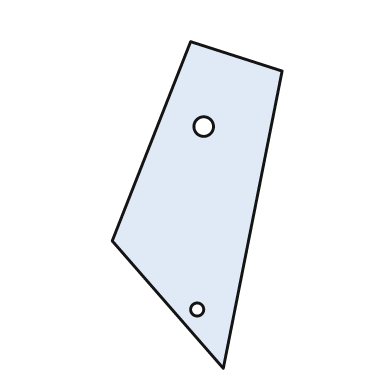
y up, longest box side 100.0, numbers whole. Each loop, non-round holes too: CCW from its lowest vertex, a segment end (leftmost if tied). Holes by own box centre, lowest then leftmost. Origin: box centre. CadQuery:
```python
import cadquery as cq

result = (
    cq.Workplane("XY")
    .moveTo(8.0, -50.0)
    .lineTo(26.0, 41.0)
    .lineTo(-2.0, 50.0)
    .lineTo(-26.0, -11.0)
    .close()
    .moveTo(0.0, -32.0)
    .circle(2.0)
    .moveTo(2.0, 24.0)
    .circle(3.0)
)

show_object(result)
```